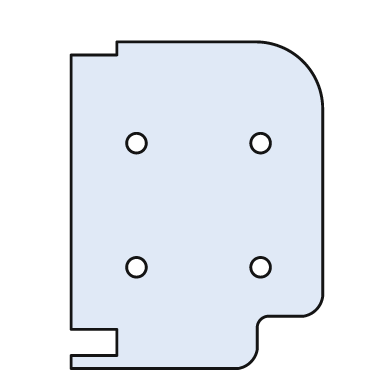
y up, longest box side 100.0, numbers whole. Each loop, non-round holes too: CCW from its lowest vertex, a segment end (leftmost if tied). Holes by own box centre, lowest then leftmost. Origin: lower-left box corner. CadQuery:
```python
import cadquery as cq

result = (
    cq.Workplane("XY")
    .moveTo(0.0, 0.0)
    .lineTo(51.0, 0.0)
    .threePointArc((55.0, 2.0), (57.0, 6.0))
    .lineTo(57.0, 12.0)
    .threePointArc((58.0, 15.0), (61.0, 16.0))
    .lineTo(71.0, 16.0)
    .threePointArc((75.0, 18.0), (77.0, 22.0))
    .lineTo(77.0, 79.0)
    .threePointArc((71.0, 94.0), (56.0, 100.0))
    .lineTo(14.0, 100.0)
    .lineTo(14.0, 96.0)
    .lineTo(0.0, 96.0)
    .lineTo(0.0, 12.0)
    .lineTo(14.0, 12.0)
    .lineTo(14.0, 4.0)
    .lineTo(0.0, 4.0)
    .close()
    .moveTo(20.0, 31.0)
    .circle(3.0)
    .moveTo(58.0, 31.0)
    .circle(3.0)
    .moveTo(20.0, 69.0)
    .circle(3.0)
    .moveTo(58.0, 69.0)
    .circle(3.0)
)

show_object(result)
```